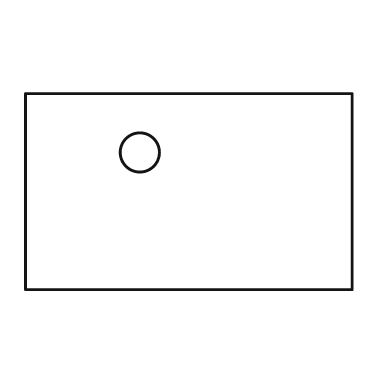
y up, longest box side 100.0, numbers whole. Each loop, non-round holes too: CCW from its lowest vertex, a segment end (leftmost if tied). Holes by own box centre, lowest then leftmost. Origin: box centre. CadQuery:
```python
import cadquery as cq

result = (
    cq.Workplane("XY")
    .moveTo(-50.0, -30.0)
    .lineTo(50.0, -30.0)
    .lineTo(50.0, 30.0)
    .lineTo(-50.0, 30.0)
    .close()
    .moveTo(-15.0, 12.0)
    .circle(6.0)
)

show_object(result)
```